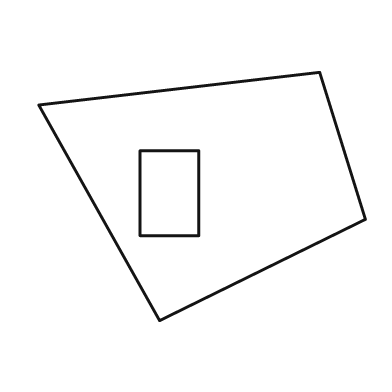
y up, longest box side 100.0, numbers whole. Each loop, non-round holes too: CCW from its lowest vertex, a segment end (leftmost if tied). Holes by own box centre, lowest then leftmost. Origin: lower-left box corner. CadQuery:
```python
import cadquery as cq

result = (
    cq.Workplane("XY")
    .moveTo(37.0, 0.0)
    .lineTo(100.0, 31.0)
    .lineTo(86.0, 76.0)
    .lineTo(0.0, 66.0)
    .close()
    .moveTo(31.0, 26.0)
    .lineTo(49.0, 26.0)
    .lineTo(49.0, 52.0)
    .lineTo(31.0, 52.0)
    .close()
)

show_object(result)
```